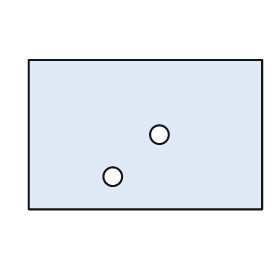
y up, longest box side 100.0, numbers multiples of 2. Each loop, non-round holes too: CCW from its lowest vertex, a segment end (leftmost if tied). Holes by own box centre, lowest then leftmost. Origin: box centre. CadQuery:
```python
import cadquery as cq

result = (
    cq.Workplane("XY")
    .moveTo(-50.0, -32.0)
    .lineTo(50.0, -32.0)
    .lineTo(50.0, 32.0)
    .lineTo(-50.0, 32.0)
    .close()
    .moveTo(-14.0, -18.0)
    .circle(4.0)
    .moveTo(6.0, 0.0)
    .circle(4.0)
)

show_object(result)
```